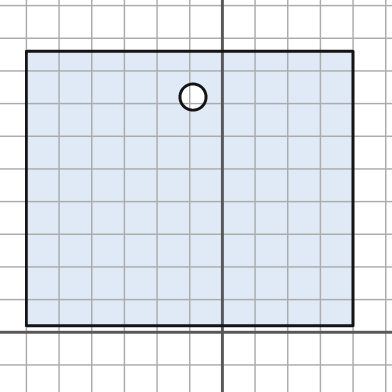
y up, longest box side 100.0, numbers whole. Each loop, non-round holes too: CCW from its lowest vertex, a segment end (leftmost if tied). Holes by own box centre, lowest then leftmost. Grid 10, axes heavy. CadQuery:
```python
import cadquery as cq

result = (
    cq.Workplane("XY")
    .moveTo(-60.0, 2.0)
    .lineTo(40.0, 2.0)
    .lineTo(40.0, 86.0)
    .lineTo(-60.0, 86.0)
    .close()
    .moveTo(-9.0, 72.0)
    .circle(4.0)
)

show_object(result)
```